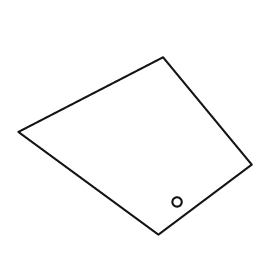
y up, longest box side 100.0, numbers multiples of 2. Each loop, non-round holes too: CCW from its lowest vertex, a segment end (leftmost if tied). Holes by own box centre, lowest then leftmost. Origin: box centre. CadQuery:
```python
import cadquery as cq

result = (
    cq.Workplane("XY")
    .moveTo(10.0, -38.0)
    .lineTo(50.0, -8.0)
    .lineTo(12.0, 38.0)
    .lineTo(-50.0, 6.0)
    .close()
    .moveTo(18.0, -24.0)
    .circle(2.0)
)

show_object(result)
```